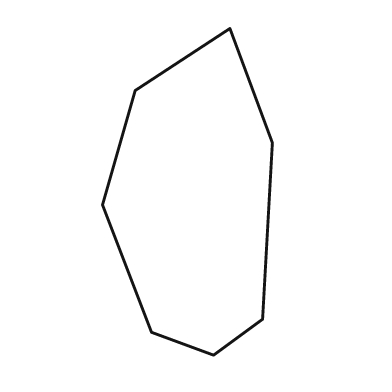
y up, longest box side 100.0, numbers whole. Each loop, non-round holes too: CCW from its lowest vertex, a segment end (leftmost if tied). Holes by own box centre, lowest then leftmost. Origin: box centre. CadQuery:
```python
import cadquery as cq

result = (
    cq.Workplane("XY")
    .moveTo(8.0, -50.0)
    .lineTo(23.0, -39.0)
    .lineTo(26.0, 15.0)
    .lineTo(13.0, 50.0)
    .lineTo(-16.0, 31.0)
    .lineTo(-26.0, -4.0)
    .lineTo(-11.0, -43.0)
    .close()
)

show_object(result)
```